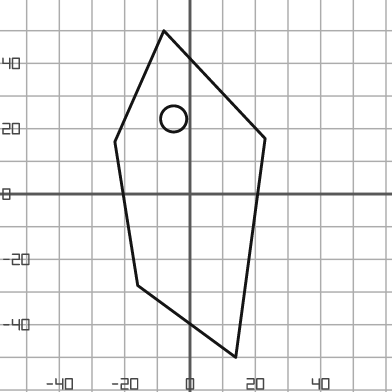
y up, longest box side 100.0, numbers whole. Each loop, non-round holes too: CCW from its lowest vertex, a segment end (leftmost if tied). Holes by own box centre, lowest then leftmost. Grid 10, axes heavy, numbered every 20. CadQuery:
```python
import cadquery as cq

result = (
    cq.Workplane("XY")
    .moveTo(14.0, -50.0)
    .lineTo(23.0, 17.0)
    .lineTo(-8.0, 50.0)
    .lineTo(-23.0, 16.0)
    .lineTo(-16.0, -28.0)
    .close()
    .moveTo(-5.0, 23.0)
    .circle(4.0)
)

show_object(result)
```